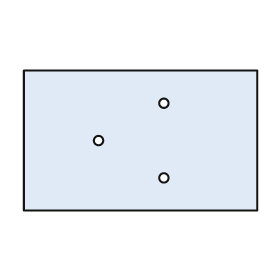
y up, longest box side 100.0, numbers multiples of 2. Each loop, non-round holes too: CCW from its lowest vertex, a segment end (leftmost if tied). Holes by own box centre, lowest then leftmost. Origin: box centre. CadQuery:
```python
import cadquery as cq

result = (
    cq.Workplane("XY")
    .moveTo(-50.0, -30.0)
    .lineTo(50.0, -30.0)
    .lineTo(50.0, 30.0)
    .lineTo(-50.0, 30.0)
    .close()
    .moveTo(10.0, -16.0)
    .circle(2.0)
    .moveTo(-18.0, 0.0)
    .circle(2.0)
    .moveTo(10.0, 16.0)
    .circle(2.0)
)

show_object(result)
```